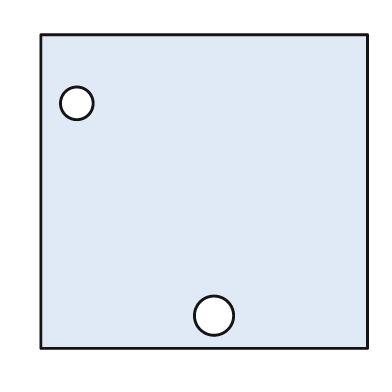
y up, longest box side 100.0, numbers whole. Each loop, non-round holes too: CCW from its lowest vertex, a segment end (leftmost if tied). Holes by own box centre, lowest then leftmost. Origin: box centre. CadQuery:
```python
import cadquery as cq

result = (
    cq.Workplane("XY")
    .moveTo(-50.0, -48.0)
    .lineTo(50.0, -48.0)
    .lineTo(50.0, 48.0)
    .lineTo(-50.0, 48.0)
    .close()
    .moveTo(3.0, -38.0)
    .circle(6.0)
    .moveTo(-39.0, 27.0)
    .circle(5.0)
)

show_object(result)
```